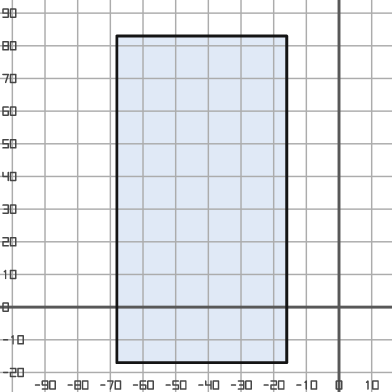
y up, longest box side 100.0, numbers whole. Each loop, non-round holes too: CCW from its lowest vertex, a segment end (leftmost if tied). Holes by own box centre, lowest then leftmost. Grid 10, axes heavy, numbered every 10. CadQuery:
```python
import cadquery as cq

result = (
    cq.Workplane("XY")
    .moveTo(-68.0, -17.0)
    .lineTo(-16.0, -17.0)
    .lineTo(-16.0, 83.0)
    .lineTo(-68.0, 83.0)
    .close()
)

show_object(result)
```